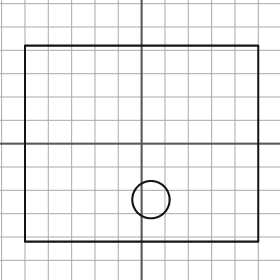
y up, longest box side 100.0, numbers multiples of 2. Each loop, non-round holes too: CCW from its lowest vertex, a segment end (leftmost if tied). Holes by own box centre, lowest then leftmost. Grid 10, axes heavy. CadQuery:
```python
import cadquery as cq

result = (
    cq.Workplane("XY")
    .moveTo(-50.0, -42.0)
    .lineTo(50.0, -42.0)
    .lineTo(50.0, 42.0)
    .lineTo(-50.0, 42.0)
    .close()
    .moveTo(4.0, -24.0)
    .circle(8.0)
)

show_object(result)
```